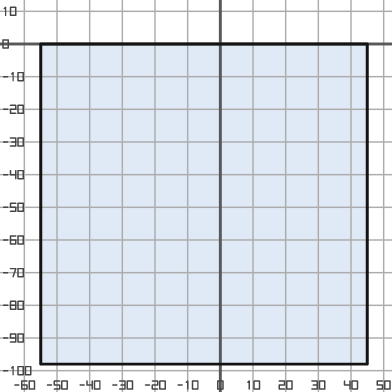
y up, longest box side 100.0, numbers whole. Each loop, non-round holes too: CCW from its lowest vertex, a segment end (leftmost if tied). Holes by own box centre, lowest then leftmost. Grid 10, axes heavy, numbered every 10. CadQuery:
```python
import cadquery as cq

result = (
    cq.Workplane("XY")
    .moveTo(-55.0, -98.0)
    .lineTo(45.0, -98.0)
    .lineTo(45.0, 0.0)
    .lineTo(-55.0, 0.0)
    .close()
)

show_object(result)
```